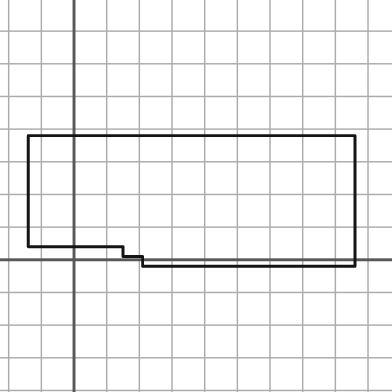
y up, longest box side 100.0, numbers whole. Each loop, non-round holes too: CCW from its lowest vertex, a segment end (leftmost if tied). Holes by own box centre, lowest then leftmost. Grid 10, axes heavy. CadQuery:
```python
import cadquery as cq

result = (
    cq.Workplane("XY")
    .moveTo(21.0, -2.0)
    .lineTo(86.0, -2.0)
    .lineTo(86.0, 38.0)
    .lineTo(-14.0, 38.0)
    .lineTo(-14.0, 4.0)
    .lineTo(15.0, 4.0)
    .lineTo(15.0, 1.0)
    .lineTo(21.0, 1.0)
    .close()
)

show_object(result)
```